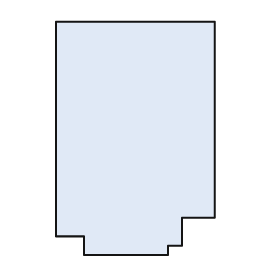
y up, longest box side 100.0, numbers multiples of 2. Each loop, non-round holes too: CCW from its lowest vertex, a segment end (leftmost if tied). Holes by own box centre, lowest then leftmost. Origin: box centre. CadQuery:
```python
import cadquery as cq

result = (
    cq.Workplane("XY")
    .moveTo(-22.0, -50.0)
    .lineTo(14.0, -50.0)
    .lineTo(14.0, -46.0)
    .lineTo(20.0, -46.0)
    .lineTo(20.0, -34.0)
    .lineTo(34.0, -34.0)
    .lineTo(34.0, 50.0)
    .lineTo(-34.0, 50.0)
    .lineTo(-34.0, -42.0)
    .lineTo(-22.0, -42.0)
    .close()
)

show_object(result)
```